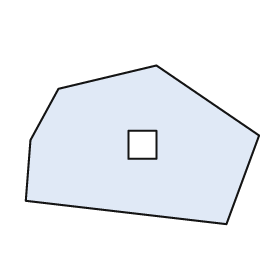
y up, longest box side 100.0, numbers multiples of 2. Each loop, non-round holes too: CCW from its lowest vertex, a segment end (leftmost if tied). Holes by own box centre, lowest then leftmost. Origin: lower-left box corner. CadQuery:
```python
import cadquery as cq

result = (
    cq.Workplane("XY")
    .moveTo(86.0, 0.0)
    .lineTo(100.0, 38.0)
    .lineTo(56.0, 68.0)
    .lineTo(14.0, 58.0)
    .lineTo(2.0, 36.0)
    .lineTo(0.0, 10.0)
    .close()
    .moveTo(44.0, 28.0)
    .lineTo(56.0, 28.0)
    .lineTo(56.0, 40.0)
    .lineTo(44.0, 40.0)
    .close()
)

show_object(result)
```